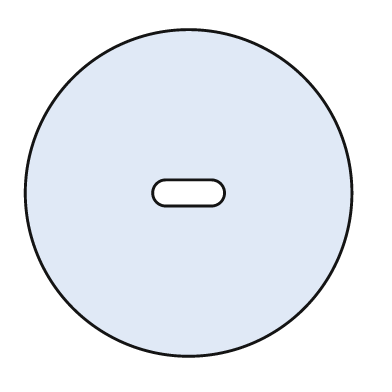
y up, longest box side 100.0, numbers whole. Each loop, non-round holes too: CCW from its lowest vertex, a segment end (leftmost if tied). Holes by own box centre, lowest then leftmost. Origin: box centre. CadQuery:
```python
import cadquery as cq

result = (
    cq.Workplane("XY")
    .moveTo(0.0, 0.0)
    .circle(50.0)
    .moveTo(-7.0, -4.0)
    .lineTo(7.0, -4.0)
    .threePointArc((11.0, 0.0), (7.0, 4.0))
    .lineTo(-7.0, 4.0)
    .threePointArc((-11.0, 0.0), (-7.0, -4.0))
    .close()
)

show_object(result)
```